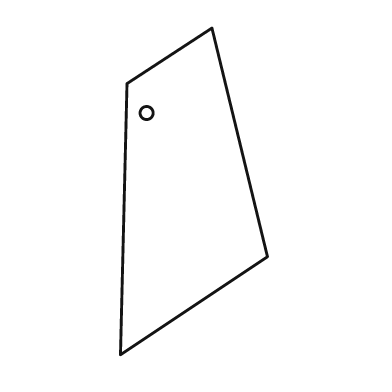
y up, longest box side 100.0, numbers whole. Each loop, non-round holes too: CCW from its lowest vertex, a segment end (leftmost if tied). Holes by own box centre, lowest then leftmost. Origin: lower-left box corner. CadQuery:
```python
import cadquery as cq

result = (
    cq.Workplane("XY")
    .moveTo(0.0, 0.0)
    .lineTo(45.0, 30.0)
    .lineTo(28.0, 100.0)
    .lineTo(2.0, 83.0)
    .close()
    .moveTo(8.0, 74.0)
    .circle(2.0)
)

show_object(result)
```